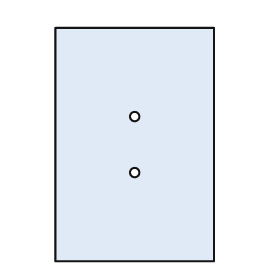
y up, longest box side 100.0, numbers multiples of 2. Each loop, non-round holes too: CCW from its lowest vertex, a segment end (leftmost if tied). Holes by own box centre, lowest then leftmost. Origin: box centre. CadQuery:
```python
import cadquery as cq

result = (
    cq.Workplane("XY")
    .moveTo(-34.0, -50.0)
    .lineTo(34.0, -50.0)
    .lineTo(34.0, 50.0)
    .lineTo(-34.0, 50.0)
    .close()
    .moveTo(0.0, -12.0)
    .circle(2.0)
    .moveTo(0.0, 12.0)
    .circle(2.0)
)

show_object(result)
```